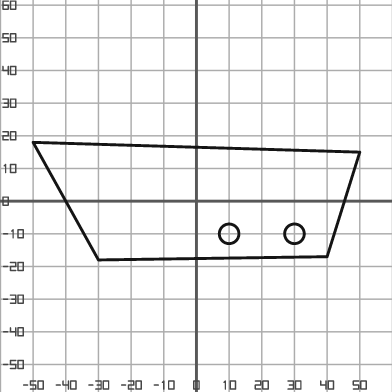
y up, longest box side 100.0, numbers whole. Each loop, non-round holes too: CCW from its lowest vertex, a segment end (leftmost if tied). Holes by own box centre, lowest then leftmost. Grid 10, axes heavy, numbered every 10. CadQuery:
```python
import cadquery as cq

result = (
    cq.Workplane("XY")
    .moveTo(-30.0, -18.0)
    .lineTo(40.0, -17.0)
    .lineTo(50.0, 15.0)
    .lineTo(-50.0, 18.0)
    .close()
    .moveTo(10.0, -10.0)
    .circle(3.0)
    .moveTo(30.0, -10.0)
    .circle(3.0)
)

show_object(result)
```